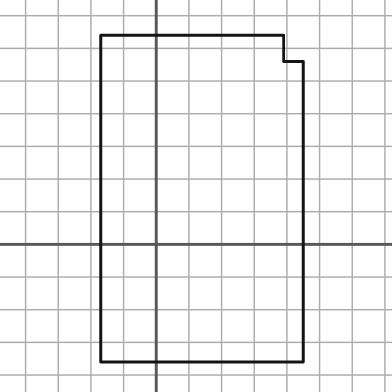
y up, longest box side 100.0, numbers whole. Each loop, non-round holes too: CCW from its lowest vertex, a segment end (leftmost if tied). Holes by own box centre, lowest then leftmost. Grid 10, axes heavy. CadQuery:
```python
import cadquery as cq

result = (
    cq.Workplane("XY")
    .moveTo(-17.0, -36.0)
    .lineTo(45.0, -36.0)
    .lineTo(45.0, 56.0)
    .lineTo(39.0, 56.0)
    .lineTo(39.0, 64.0)
    .lineTo(-17.0, 64.0)
    .close()
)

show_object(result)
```